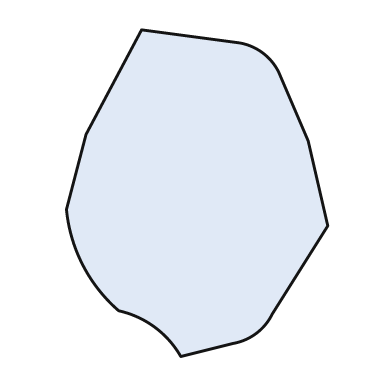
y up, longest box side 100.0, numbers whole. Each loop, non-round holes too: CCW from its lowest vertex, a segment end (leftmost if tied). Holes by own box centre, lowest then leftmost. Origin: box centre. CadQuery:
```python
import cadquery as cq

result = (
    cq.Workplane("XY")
    .moveTo(-5.0, -50.0)
    .lineTo(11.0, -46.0)
    .threePointArc((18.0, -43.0), (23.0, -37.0))
    .lineTo(40.0, -10.0)
    .lineTo(34.0, 16.0)
    .lineTo(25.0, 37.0)
    .threePointArc((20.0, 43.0), (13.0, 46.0))
    .lineTo(-17.0, 50.0)
    .lineTo(-34.0, 18.0)
    .lineTo(-40.0, -5.0)
    .threePointArc((-35.0, -22.0), (-24.0, -36.0))
    .threePointArc((-13.0, -41.0), (-5.0, -50.0))
    .close()
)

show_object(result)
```